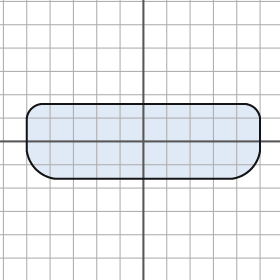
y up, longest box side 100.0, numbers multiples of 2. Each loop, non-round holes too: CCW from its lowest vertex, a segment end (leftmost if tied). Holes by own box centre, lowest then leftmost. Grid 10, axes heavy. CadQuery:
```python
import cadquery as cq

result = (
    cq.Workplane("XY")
    .moveTo(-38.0, -16.0)
    .lineTo(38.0, -16.0)
    .threePointArc((46.0, -12.0), (50.0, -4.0))
    .lineTo(50.0, 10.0)
    .threePointArc((48.0, 14.0), (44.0, 16.0))
    .lineTo(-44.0, 16.0)
    .threePointArc((-48.0, 14.0), (-50.0, 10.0))
    .lineTo(-50.0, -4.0)
    .threePointArc((-46.0, -12.0), (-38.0, -16.0))
    .close()
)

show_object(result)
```